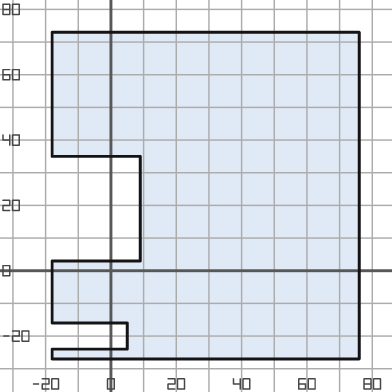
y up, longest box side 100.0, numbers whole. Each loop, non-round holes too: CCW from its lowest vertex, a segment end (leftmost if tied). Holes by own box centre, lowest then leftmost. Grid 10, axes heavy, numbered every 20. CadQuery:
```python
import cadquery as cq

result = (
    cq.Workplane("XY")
    .moveTo(-18.0, -27.0)
    .lineTo(76.0, -27.0)
    .lineTo(76.0, 73.0)
    .lineTo(-18.0, 73.0)
    .lineTo(-18.0, 35.0)
    .lineTo(9.0, 35.0)
    .lineTo(9.0, 3.0)
    .lineTo(-18.0, 3.0)
    .lineTo(-18.0, -16.0)
    .lineTo(5.0, -16.0)
    .lineTo(5.0, -24.0)
    .lineTo(-18.0, -24.0)
    .close()
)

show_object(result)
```